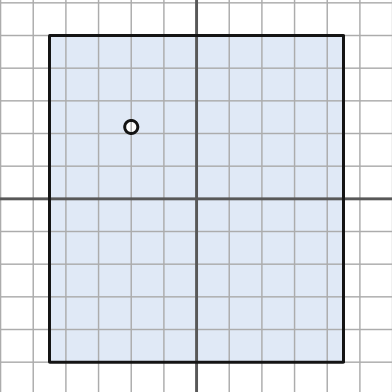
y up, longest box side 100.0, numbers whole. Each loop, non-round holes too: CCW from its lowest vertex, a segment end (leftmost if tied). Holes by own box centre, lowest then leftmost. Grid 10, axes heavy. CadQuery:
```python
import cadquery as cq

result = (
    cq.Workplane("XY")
    .moveTo(-45.0, -50.0)
    .lineTo(45.0, -50.0)
    .lineTo(45.0, 50.0)
    .lineTo(-45.0, 50.0)
    .close()
    .moveTo(-20.0, 22.0)
    .circle(2.0)
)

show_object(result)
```